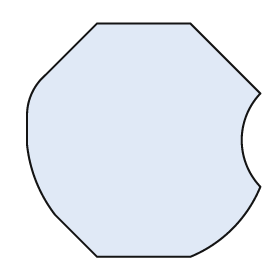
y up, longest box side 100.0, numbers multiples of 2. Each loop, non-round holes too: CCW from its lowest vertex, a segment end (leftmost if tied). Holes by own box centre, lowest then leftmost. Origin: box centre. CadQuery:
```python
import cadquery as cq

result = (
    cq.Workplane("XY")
    .moveTo(-20.0, -50.0)
    .lineTo(20.0, -50.0)
    .threePointArc((38.0, -38.0), (50.0, -20.0))
    .threePointArc((42.0, 0.0), (50.0, 20.0))
    .lineTo(20.0, 50.0)
    .lineTo(-20.0, 50.0)
    .lineTo(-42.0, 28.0)
    .threePointArc((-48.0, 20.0), (-50.0, 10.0))
    .lineTo(-50.0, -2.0)
    .threePointArc((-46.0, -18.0), (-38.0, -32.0))
    .close()
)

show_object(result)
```